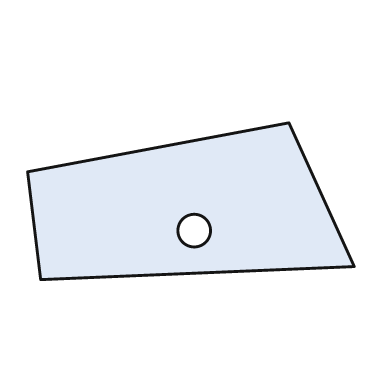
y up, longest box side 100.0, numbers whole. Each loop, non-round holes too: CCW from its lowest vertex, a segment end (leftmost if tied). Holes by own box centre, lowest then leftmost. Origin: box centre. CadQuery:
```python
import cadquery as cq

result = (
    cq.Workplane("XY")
    .moveTo(-46.0, -24.0)
    .lineTo(50.0, -20.0)
    .lineTo(30.0, 24.0)
    .lineTo(-50.0, 9.0)
    .close()
    .moveTo(1.0, -9.0)
    .circle(5.0)
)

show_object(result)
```